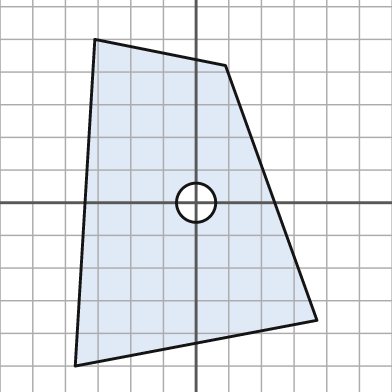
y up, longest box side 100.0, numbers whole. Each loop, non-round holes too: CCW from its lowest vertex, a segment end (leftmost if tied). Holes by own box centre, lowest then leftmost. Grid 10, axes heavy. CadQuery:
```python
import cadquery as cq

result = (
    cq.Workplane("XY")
    .moveTo(-37.0, -50.0)
    .lineTo(37.0, -36.0)
    .lineTo(9.0, 42.0)
    .lineTo(-31.0, 50.0)
    .close()
    .moveTo(0.0, 0.0)
    .circle(6.0)
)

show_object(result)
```